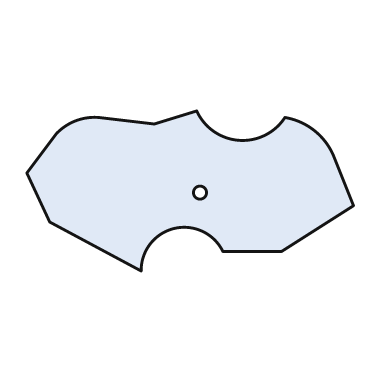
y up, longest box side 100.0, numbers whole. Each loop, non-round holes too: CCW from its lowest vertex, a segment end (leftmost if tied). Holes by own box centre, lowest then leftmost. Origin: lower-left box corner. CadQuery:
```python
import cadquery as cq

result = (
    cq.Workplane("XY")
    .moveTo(35.0, 0.0)
    .threePointArc((45.0, 13.0), (60.0, 6.0))
    .lineTo(78.0, 6.0)
    .lineTo(100.0, 20.0)
    .lineTo(94.0, 35.0)
    .threePointArc((88.0, 43.0), (79.0, 47.0))
    .threePointArc((65.0, 40.0), (52.0, 49.0))
    .lineTo(39.0, 45.0)
    .lineTo(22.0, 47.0)
    .threePointArc((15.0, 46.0), (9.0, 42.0))
    .lineTo(0.0, 30.0)
    .lineTo(7.0, 15.0)
    .close()
    .moveTo(53.0, 24.0)
    .circle(2.0)
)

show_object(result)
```